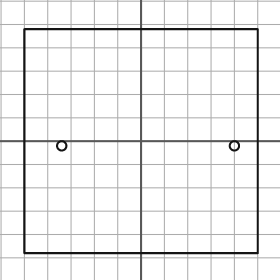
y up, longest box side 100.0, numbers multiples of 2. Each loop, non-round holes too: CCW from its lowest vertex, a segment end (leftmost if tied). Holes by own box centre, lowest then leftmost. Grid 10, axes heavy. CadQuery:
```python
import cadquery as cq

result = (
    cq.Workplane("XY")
    .moveTo(-50.0, -48.0)
    .lineTo(50.0, -48.0)
    .lineTo(50.0, 48.0)
    .lineTo(-50.0, 48.0)
    .close()
    .moveTo(-34.0, -2.0)
    .circle(2.0)
    .moveTo(40.0, -2.0)
    .circle(2.0)
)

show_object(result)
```